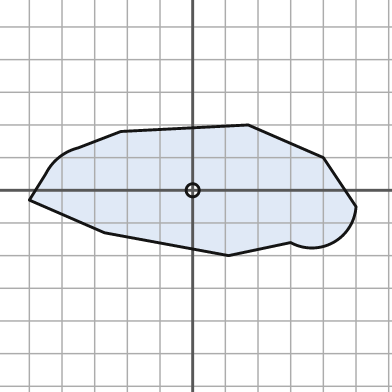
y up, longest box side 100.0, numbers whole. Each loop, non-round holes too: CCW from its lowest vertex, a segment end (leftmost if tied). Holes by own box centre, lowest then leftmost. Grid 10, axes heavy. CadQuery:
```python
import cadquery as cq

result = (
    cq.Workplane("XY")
    .moveTo(11.0, -20.0)
    .lineTo(30.0, -16.0)
    .threePointArc((43.0, -16.0), (50.0, -5.0))
    .lineTo(40.0, 10.0)
    .lineTo(17.0, 20.0)
    .lineTo(-22.0, 18.0)
    .lineTo(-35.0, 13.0)
    .threePointArc((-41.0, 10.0), (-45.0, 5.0))
    .lineTo(-50.0, -3.0)
    .lineTo(-27.0, -13.0)
    .close()
    .moveTo(0.0, 0.0)
    .circle(2.0)
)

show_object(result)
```